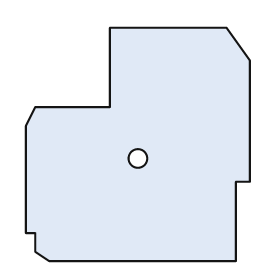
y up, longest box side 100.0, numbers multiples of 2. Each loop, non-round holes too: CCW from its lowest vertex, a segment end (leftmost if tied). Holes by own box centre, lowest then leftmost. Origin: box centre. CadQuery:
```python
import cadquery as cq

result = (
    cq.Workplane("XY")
    .moveTo(-38.0, -50.0)
    .lineTo(42.0, -50.0)
    .lineTo(42.0, -16.0)
    .lineTo(48.0, -16.0)
    .lineTo(48.0, 36.0)
    .lineTo(38.0, 50.0)
    .lineTo(-12.0, 50.0)
    .lineTo(-12.0, 16.0)
    .lineTo(-44.0, 16.0)
    .lineTo(-48.0, 8.0)
    .lineTo(-48.0, -38.0)
    .lineTo(-44.0, -38.0)
    .lineTo(-44.0, -46.0)
    .close()
    .moveTo(0.0, -6.0)
    .circle(4.0)
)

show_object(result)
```